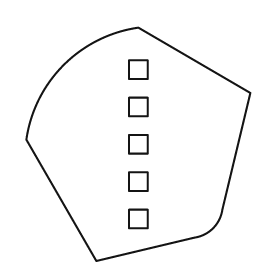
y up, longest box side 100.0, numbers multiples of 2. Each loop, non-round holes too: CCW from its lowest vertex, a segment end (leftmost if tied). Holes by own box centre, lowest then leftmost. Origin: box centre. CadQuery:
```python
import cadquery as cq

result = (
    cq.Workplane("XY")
    .moveTo(-18.0, -50.0)
    .lineTo(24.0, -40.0)
    .threePointArc((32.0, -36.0), (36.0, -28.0))
    .lineTo(48.0, 22.0)
    .lineTo(0.0, 50.0)
    .threePointArc((-32.0, 34.0), (-48.0, 2.0))
    .close()
    .moveTo(-4.0, -36.0)
    .lineTo(4.0, -36.0)
    .lineTo(4.0, -28.0)
    .lineTo(-4.0, -28.0)
    .close()
    .moveTo(-4.0, -20.0)
    .lineTo(4.0, -20.0)
    .lineTo(4.0, -12.0)
    .lineTo(-4.0, -12.0)
    .close()
    .moveTo(-4.0, -4.0)
    .lineTo(4.0, -4.0)
    .lineTo(4.0, 4.0)
    .lineTo(-4.0, 4.0)
    .close()
    .moveTo(-4.0, 12.0)
    .lineTo(4.0, 12.0)
    .lineTo(4.0, 20.0)
    .lineTo(-4.0, 20.0)
    .close()
    .moveTo(-4.0, 28.0)
    .lineTo(4.0, 28.0)
    .lineTo(4.0, 36.0)
    .lineTo(-4.0, 36.0)
    .close()
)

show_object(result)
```